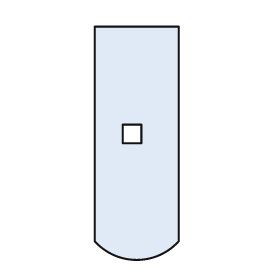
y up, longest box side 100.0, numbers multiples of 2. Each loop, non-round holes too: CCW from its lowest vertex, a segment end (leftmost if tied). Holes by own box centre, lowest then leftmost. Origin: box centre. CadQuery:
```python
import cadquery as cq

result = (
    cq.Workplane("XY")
    .moveTo(-18.0, -42.0)
    .threePointArc((0.0, -50.0), (18.0, -42.0))
    .lineTo(18.0, 50.0)
    .lineTo(-18.0, 50.0)
    .close()
    .moveTo(-6.0, 0.0)
    .lineTo(2.0, 0.0)
    .lineTo(2.0, 8.0)
    .lineTo(-6.0, 8.0)
    .close()
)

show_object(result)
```